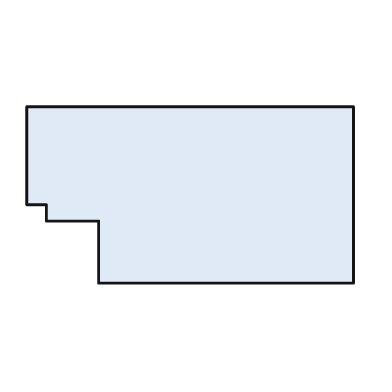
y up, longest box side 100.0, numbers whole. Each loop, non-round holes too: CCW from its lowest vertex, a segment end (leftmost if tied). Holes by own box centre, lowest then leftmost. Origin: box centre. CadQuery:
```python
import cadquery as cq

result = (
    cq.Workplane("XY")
    .moveTo(-28.0, -27.0)
    .lineTo(50.0, -27.0)
    .lineTo(50.0, 27.0)
    .lineTo(-50.0, 27.0)
    .lineTo(-50.0, -3.0)
    .lineTo(-44.0, -3.0)
    .lineTo(-44.0, -8.0)
    .lineTo(-28.0, -8.0)
    .close()
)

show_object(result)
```